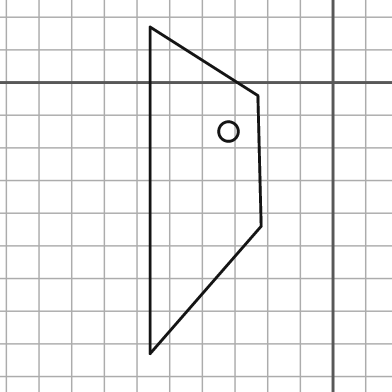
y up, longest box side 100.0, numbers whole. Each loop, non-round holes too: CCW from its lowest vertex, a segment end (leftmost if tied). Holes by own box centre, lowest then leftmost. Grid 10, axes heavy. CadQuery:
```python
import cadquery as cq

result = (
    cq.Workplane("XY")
    .moveTo(-56.0, -83.0)
    .lineTo(-22.0, -44.0)
    .lineTo(-23.0, -4.0)
    .lineTo(-56.0, 17.0)
    .close()
    .moveTo(-32.0, -15.0)
    .circle(3.0)
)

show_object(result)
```